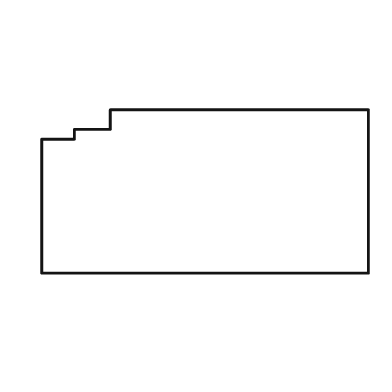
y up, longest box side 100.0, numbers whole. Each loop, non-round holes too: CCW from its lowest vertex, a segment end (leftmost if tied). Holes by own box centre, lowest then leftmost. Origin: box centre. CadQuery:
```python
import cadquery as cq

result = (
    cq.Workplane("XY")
    .moveTo(-50.0, -25.0)
    .lineTo(50.0, -25.0)
    .lineTo(50.0, 25.0)
    .lineTo(-29.0, 25.0)
    .lineTo(-29.0, 19.0)
    .lineTo(-40.0, 19.0)
    .lineTo(-40.0, 16.0)
    .lineTo(-50.0, 16.0)
    .close()
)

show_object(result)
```